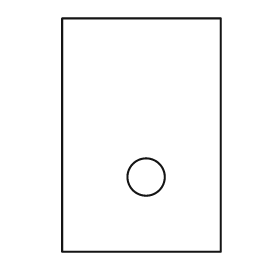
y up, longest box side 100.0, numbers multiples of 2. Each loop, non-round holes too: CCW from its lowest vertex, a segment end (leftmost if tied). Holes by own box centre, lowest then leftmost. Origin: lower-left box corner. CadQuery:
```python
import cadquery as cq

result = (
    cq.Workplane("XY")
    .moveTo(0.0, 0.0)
    .lineTo(68.0, 0.0)
    .lineTo(68.0, 100.0)
    .lineTo(0.0, 100.0)
    .close()
    .moveTo(36.0, 32.0)
    .circle(8.0)
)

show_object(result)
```